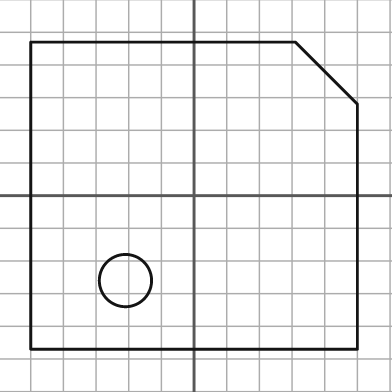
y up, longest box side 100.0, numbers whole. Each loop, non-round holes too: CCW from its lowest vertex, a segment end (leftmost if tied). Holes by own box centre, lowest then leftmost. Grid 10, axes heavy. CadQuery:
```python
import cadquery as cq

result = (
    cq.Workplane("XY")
    .moveTo(-50.0, -47.0)
    .lineTo(50.0, -47.0)
    .lineTo(50.0, 28.0)
    .lineTo(31.0, 47.0)
    .lineTo(-50.0, 47.0)
    .close()
    .moveTo(-21.0, -26.0)
    .circle(8.0)
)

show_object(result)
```